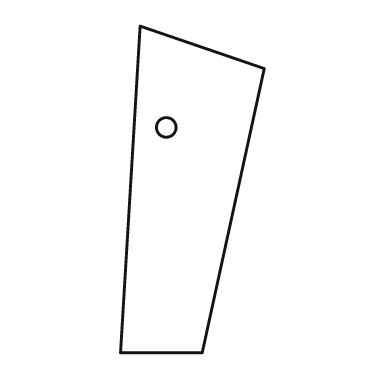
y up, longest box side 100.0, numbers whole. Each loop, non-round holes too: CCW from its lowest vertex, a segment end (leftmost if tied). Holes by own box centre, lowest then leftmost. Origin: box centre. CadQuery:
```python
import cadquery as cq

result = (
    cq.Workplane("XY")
    .moveTo(-22.0, -50.0)
    .lineTo(3.0, -50.0)
    .lineTo(22.0, 37.0)
    .lineTo(-16.0, 50.0)
    .close()
    .moveTo(-8.0, 19.0)
    .circle(3.0)
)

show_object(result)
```